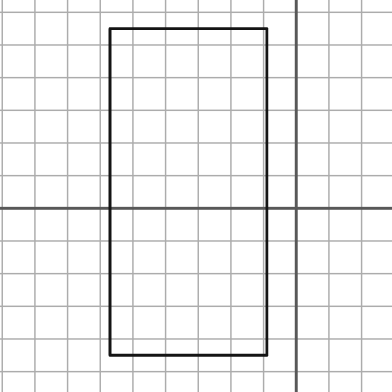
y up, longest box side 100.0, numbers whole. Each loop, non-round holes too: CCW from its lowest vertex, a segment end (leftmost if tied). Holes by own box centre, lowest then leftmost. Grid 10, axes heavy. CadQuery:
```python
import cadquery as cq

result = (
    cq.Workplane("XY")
    .moveTo(-57.0, -45.0)
    .lineTo(-9.0, -45.0)
    .lineTo(-9.0, 55.0)
    .lineTo(-57.0, 55.0)
    .close()
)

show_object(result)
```